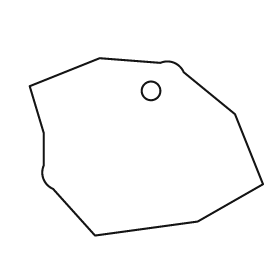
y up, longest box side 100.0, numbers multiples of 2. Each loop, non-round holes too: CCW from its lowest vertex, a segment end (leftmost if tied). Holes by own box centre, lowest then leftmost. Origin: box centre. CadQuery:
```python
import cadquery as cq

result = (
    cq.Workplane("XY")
    .moveTo(-22.0, -38.0)
    .lineTo(22.0, -32.0)
    .lineTo(50.0, -16.0)
    .lineTo(38.0, 14.0)
    .lineTo(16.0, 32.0)
    .threePointArc((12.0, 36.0), (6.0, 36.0))
    .lineTo(-20.0, 38.0)
    .lineTo(-50.0, 26.0)
    .lineTo(-44.0, 6.0)
    .lineTo(-44.0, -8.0)
    .threePointArc((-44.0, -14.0), (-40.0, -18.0))
    .close()
    .moveTo(2.0, 24.0)
    .circle(4.0)
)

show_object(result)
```